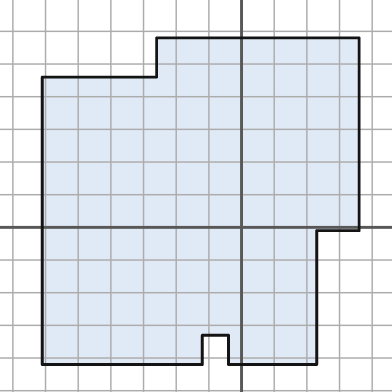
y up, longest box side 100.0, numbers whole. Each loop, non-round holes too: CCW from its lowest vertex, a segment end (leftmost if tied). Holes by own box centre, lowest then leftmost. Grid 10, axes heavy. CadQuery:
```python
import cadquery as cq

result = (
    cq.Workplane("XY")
    .moveTo(-61.0, -42.0)
    .lineTo(-12.0, -42.0)
    .lineTo(-12.0, -33.0)
    .lineTo(-4.0, -33.0)
    .lineTo(-4.0, -42.0)
    .lineTo(23.0, -42.0)
    .lineTo(23.0, -1.0)
    .lineTo(36.0, -1.0)
    .lineTo(36.0, 58.0)
    .lineTo(-26.0, 58.0)
    .lineTo(-26.0, 46.0)
    .lineTo(-61.0, 46.0)
    .close()
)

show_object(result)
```